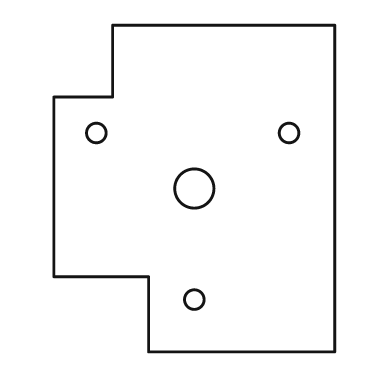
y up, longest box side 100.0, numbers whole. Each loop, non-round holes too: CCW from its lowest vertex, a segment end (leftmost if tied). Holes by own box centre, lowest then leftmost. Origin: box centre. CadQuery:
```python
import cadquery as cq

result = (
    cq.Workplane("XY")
    .moveTo(-14.0, -50.0)
    .lineTo(43.0, -50.0)
    .lineTo(43.0, 50.0)
    .lineTo(-25.0, 50.0)
    .lineTo(-25.0, 28.0)
    .lineTo(-43.0, 28.0)
    .lineTo(-43.0, -27.0)
    .lineTo(-14.0, -27.0)
    .close()
    .moveTo(0.0, -34.0)
    .circle(3.0)
    .moveTo(0.0, 0.0)
    .circle(6.0)
    .moveTo(-30.0, 17.0)
    .circle(3.0)
    .moveTo(29.0, 17.0)
    .circle(3.0)
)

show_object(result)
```